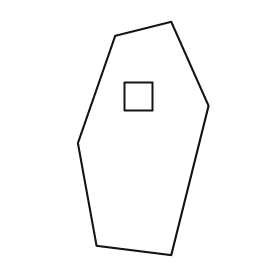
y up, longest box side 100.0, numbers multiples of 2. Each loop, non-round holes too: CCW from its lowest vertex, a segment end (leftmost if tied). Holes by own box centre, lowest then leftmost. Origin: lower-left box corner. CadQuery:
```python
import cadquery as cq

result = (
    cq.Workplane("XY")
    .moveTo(40.0, 0.0)
    .lineTo(56.0, 64.0)
    .lineTo(40.0, 100.0)
    .lineTo(16.0, 94.0)
    .lineTo(0.0, 48.0)
    .lineTo(8.0, 4.0)
    .close()
    .moveTo(20.0, 62.0)
    .lineTo(32.0, 62.0)
    .lineTo(32.0, 74.0)
    .lineTo(20.0, 74.0)
    .close()
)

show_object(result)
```